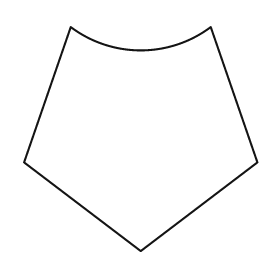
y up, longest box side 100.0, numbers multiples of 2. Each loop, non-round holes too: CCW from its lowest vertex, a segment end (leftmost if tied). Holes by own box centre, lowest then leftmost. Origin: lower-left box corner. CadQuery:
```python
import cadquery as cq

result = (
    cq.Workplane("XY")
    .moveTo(50.0, 0.0)
    .lineTo(100.0, 38.0)
    .lineTo(80.0, 96.0)
    .threePointArc((50.0, 86.0), (20.0, 96.0))
    .lineTo(0.0, 38.0)
    .close()
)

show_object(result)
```